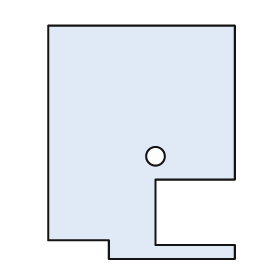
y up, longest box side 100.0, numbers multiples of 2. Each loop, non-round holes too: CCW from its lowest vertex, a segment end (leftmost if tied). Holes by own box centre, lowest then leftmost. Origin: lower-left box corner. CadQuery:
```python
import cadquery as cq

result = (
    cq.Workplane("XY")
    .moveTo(26.0, 0.0)
    .lineTo(80.0, 0.0)
    .lineTo(80.0, 6.0)
    .lineTo(46.0, 6.0)
    .lineTo(46.0, 34.0)
    .lineTo(80.0, 34.0)
    .lineTo(80.0, 100.0)
    .lineTo(0.0, 100.0)
    .lineTo(0.0, 8.0)
    .lineTo(26.0, 8.0)
    .close()
    .moveTo(46.0, 44.0)
    .circle(4.0)
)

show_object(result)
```